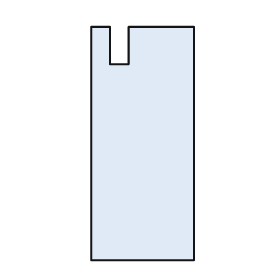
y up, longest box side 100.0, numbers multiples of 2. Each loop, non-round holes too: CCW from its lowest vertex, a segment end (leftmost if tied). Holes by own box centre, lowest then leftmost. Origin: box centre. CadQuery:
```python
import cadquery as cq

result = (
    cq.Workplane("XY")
    .moveTo(-22.0, -50.0)
    .lineTo(22.0, -50.0)
    .lineTo(22.0, 50.0)
    .lineTo(-6.0, 50.0)
    .lineTo(-6.0, 34.0)
    .lineTo(-14.0, 34.0)
    .lineTo(-14.0, 50.0)
    .lineTo(-22.0, 50.0)
    .close()
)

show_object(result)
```